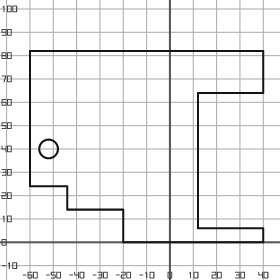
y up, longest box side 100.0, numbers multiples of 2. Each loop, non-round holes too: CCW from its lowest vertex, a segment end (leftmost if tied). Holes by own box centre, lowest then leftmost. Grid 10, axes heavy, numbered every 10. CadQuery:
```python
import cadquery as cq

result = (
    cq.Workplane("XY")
    .moveTo(-20.0, 0.0)
    .lineTo(40.0, 0.0)
    .lineTo(40.0, 6.0)
    .lineTo(12.0, 6.0)
    .lineTo(12.0, 64.0)
    .lineTo(40.0, 64.0)
    .lineTo(40.0, 82.0)
    .lineTo(-60.0, 82.0)
    .lineTo(-60.0, 24.0)
    .lineTo(-44.0, 24.0)
    .lineTo(-44.0, 14.0)
    .lineTo(-20.0, 14.0)
    .close()
    .moveTo(-52.0, 40.0)
    .circle(4.0)
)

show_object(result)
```